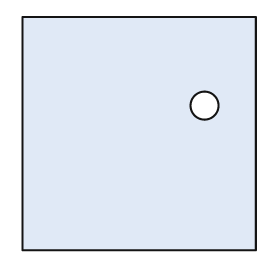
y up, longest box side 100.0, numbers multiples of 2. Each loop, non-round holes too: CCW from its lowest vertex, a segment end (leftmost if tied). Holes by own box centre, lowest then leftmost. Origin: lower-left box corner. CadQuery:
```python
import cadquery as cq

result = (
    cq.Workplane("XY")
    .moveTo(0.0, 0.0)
    .lineTo(100.0, 0.0)
    .lineTo(100.0, 100.0)
    .lineTo(0.0, 100.0)
    .close()
    .moveTo(78.0, 62.0)
    .circle(6.0)
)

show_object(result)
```